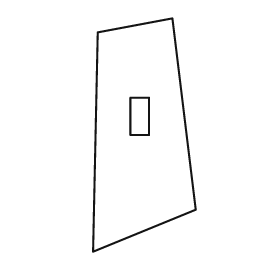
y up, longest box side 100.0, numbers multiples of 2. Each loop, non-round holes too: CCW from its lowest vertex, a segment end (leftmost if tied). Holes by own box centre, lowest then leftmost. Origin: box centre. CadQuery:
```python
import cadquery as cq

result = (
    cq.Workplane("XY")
    .moveTo(-22.0, -50.0)
    .lineTo(22.0, -32.0)
    .lineTo(12.0, 50.0)
    .lineTo(-20.0, 44.0)
    .close()
    .moveTo(-6.0, 0.0)
    .lineTo(2.0, 0.0)
    .lineTo(2.0, 16.0)
    .lineTo(-6.0, 16.0)
    .close()
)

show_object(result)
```